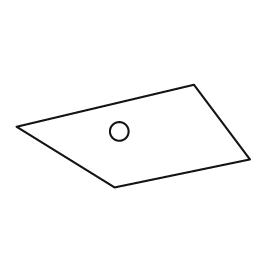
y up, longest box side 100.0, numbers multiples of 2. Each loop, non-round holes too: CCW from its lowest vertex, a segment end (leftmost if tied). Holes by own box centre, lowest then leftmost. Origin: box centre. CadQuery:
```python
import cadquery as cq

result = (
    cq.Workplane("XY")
    .moveTo(-8.0, -22.0)
    .lineTo(50.0, -10.0)
    .lineTo(26.0, 22.0)
    .lineTo(-50.0, 4.0)
    .close()
    .moveTo(-6.0, 2.0)
    .circle(4.0)
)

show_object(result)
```